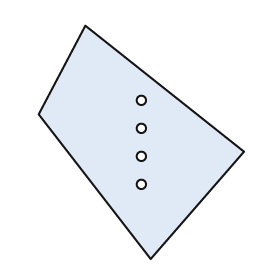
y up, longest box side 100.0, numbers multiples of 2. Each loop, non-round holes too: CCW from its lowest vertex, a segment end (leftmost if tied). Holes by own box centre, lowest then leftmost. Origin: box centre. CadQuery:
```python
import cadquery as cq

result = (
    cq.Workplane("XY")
    .moveTo(4.0, -50.0)
    .lineTo(44.0, -4.0)
    .lineTo(-24.0, 50.0)
    .lineTo(-44.0, 12.0)
    .close()
    .moveTo(0.0, -18.0)
    .circle(2.0)
    .moveTo(0.0, -6.0)
    .circle(2.0)
    .moveTo(0.0, 6.0)
    .circle(2.0)
    .moveTo(0.0, 18.0)
    .circle(2.0)
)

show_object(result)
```